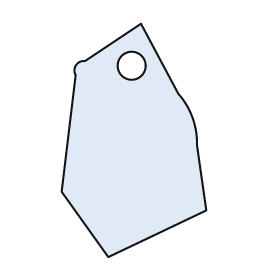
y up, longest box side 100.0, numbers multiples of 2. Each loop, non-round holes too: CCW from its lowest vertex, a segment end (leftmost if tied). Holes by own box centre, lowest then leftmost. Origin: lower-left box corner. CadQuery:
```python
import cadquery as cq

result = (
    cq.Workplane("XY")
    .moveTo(20.0, 0.0)
    .lineTo(62.0, 20.0)
    .lineTo(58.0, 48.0)
    .threePointArc((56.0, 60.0), (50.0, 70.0))
    .lineTo(34.0, 100.0)
    .lineTo(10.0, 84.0)
    .threePointArc((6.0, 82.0), (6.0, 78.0))
    .lineTo(0.0, 28.0)
    .close()
    .moveTo(30.0, 82.0)
    .circle(6.0)
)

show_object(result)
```